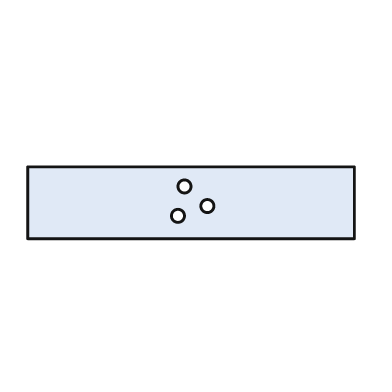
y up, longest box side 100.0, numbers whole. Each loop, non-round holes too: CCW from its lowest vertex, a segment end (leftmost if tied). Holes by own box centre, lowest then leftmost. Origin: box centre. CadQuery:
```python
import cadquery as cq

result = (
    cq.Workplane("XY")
    .moveTo(-50.0, -11.0)
    .lineTo(50.0, -11.0)
    .lineTo(50.0, 11.0)
    .lineTo(-50.0, 11.0)
    .close()
    .moveTo(-4.0, -4.0)
    .circle(2.0)
    .moveTo(5.0, -1.0)
    .circle(2.0)
    .moveTo(-2.0, 5.0)
    .circle(2.0)
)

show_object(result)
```